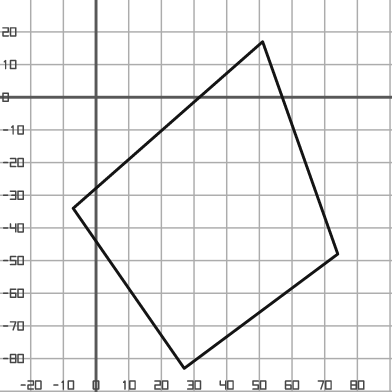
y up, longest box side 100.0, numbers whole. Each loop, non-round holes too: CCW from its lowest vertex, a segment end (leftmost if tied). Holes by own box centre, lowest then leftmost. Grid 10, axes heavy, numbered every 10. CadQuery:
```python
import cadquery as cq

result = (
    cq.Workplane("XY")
    .moveTo(27.0, -83.0)
    .lineTo(74.0, -48.0)
    .lineTo(51.0, 17.0)
    .lineTo(-7.0, -34.0)
    .close()
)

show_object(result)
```